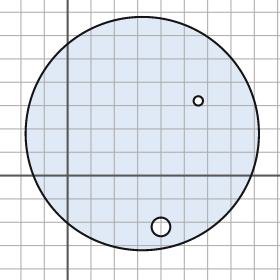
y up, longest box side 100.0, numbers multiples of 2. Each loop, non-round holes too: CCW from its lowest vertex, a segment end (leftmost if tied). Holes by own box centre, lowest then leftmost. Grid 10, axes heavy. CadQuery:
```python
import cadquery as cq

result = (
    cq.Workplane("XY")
    .moveTo(32.0, 18.0)
    .circle(50.0)
    .moveTo(40.0, -22.0)
    .circle(4.0)
    .moveTo(56.0, 32.0)
    .circle(2.0)
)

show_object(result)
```